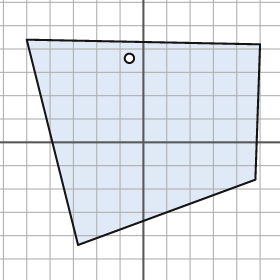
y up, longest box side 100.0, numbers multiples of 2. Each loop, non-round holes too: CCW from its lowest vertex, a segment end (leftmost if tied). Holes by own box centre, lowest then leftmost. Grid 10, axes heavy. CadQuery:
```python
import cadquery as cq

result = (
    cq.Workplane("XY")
    .moveTo(-28.0, -44.0)
    .lineTo(48.0, -16.0)
    .lineTo(50.0, 42.0)
    .lineTo(-50.0, 44.0)
    .close()
    .moveTo(-6.0, 36.0)
    .circle(2.0)
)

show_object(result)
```